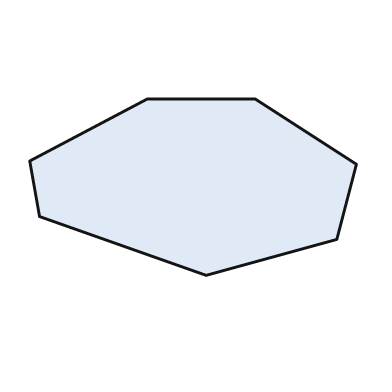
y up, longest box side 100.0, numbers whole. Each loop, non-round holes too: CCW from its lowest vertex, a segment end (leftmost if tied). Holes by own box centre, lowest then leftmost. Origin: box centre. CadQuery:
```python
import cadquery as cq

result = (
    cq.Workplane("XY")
    .moveTo(4.0, -27.0)
    .lineTo(44.0, -16.0)
    .lineTo(50.0, 7.0)
    .lineTo(19.0, 27.0)
    .lineTo(-14.0, 27.0)
    .lineTo(-50.0, 8.0)
    .lineTo(-47.0, -9.0)
    .close()
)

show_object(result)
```